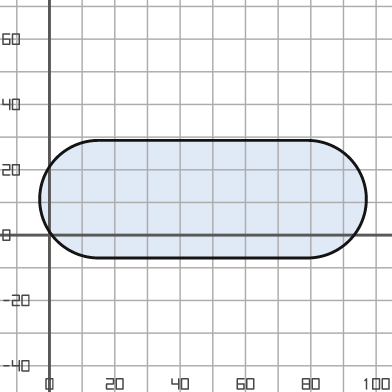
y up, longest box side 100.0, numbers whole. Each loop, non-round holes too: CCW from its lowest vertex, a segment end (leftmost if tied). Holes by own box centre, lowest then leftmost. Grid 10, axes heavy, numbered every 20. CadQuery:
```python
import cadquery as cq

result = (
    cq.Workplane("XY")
    .moveTo(15.0, -7.0)
    .lineTo(79.0, -7.0)
    .threePointArc((97.0, 11.0), (79.0, 29.0))
    .lineTo(15.0, 29.0)
    .threePointArc((-3.0, 11.0), (15.0, -7.0))
    .close()
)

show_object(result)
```